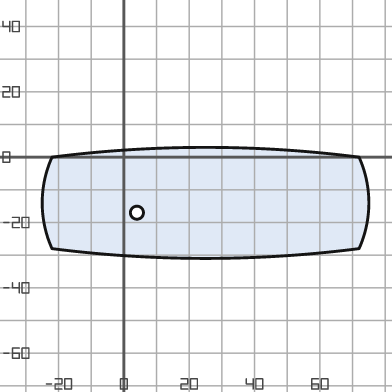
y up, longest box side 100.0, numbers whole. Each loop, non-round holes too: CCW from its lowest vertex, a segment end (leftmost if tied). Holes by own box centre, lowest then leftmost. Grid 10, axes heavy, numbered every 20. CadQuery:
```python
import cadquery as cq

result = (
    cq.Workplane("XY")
    .moveTo(-22.0, -28.0)
    .threePointArc((25.0, -31.0), (72.0, -28.0))
    .threePointArc((75.0, -14.0), (72.0, 0.0))
    .threePointArc((25.0, 3.0), (-22.0, 0.0))
    .threePointArc((-25.0, -14.0), (-22.0, -28.0))
    .close()
    .moveTo(4.0, -17.0)
    .circle(2.0)
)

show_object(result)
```